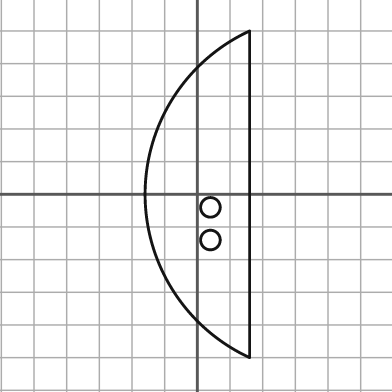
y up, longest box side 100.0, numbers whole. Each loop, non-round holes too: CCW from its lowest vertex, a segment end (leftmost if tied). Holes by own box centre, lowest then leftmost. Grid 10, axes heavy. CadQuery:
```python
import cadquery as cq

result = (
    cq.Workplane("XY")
    .moveTo(16.0, -50.0)
    .lineTo(16.0, 50.0)
    .threePointArc((-16.0, 0.0), (16.0, -50.0))
    .close()
    .moveTo(4.0, -14.0)
    .circle(3.0)
    .moveTo(4.0, -4.0)
    .circle(3.0)
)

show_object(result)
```